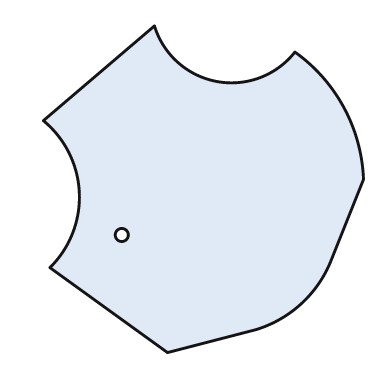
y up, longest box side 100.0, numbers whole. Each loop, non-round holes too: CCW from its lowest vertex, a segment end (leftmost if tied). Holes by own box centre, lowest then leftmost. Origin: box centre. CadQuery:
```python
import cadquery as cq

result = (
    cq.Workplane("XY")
    .moveTo(-11.0, -50.0)
    .lineTo(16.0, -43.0)
    .threePointArc((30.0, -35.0), (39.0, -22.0))
    .lineTo(49.0, 3.0)
    .threePointArc((43.0, 25.0), (28.0, 42.0))
    .threePointArc((4.0, 33.0), (-15.0, 50.0))
    .lineTo(-49.0, 21.0)
    .threePointArc((-38.0, -1.0), (-47.0, -24.0))
    .close()
    .moveTo(-25.0, -14.0)
    .circle(2.0)
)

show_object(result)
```